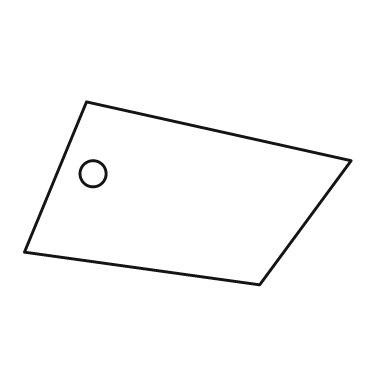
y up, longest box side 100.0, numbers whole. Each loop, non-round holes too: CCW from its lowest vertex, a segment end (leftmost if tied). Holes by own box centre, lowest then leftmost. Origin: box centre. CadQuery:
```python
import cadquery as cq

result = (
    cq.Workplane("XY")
    .moveTo(22.0, -28.0)
    .lineTo(50.0, 10.0)
    .lineTo(-31.0, 28.0)
    .lineTo(-50.0, -18.0)
    .close()
    .moveTo(-29.0, 6.0)
    .circle(4.0)
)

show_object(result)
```